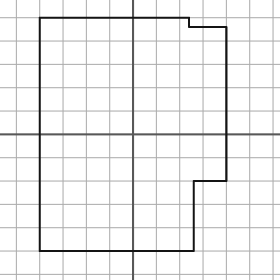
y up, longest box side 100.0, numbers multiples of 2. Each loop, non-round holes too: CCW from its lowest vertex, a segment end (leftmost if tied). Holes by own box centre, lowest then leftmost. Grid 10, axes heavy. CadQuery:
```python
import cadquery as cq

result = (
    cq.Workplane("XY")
    .moveTo(-40.0, -50.0)
    .lineTo(26.0, -50.0)
    .lineTo(26.0, -20.0)
    .lineTo(40.0, -20.0)
    .lineTo(40.0, 46.0)
    .lineTo(24.0, 46.0)
    .lineTo(24.0, 50.0)
    .lineTo(-40.0, 50.0)
    .close()
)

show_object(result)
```